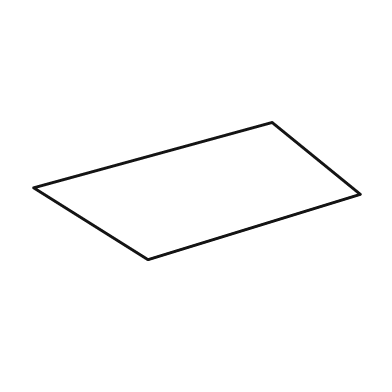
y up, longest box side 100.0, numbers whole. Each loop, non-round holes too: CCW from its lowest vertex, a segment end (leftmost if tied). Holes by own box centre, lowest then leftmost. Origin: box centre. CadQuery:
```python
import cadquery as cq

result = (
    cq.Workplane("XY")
    .moveTo(-15.0, -21.0)
    .lineTo(50.0, -1.0)
    .lineTo(23.0, 21.0)
    .lineTo(-50.0, 1.0)
    .close()
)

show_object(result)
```